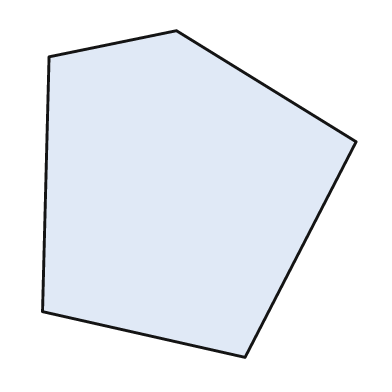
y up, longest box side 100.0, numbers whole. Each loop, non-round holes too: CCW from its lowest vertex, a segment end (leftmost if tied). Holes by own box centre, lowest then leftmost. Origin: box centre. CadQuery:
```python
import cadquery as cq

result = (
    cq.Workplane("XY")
    .moveTo(14.0, -50.0)
    .lineTo(48.0, 16.0)
    .lineTo(-7.0, 50.0)
    .lineTo(-46.0, 42.0)
    .lineTo(-48.0, -36.0)
    .close()
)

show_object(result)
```